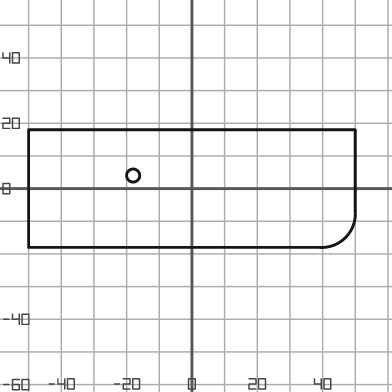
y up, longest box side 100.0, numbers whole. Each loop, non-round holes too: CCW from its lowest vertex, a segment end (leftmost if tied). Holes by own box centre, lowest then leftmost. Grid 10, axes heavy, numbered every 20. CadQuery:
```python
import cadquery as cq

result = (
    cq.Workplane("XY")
    .moveTo(-50.0, -18.0)
    .lineTo(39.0, -18.0)
    .threePointArc((47.0, -15.0), (50.0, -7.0))
    .lineTo(50.0, 18.0)
    .lineTo(-50.0, 18.0)
    .close()
    .moveTo(-18.0, 4.0)
    .circle(2.0)
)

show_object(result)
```